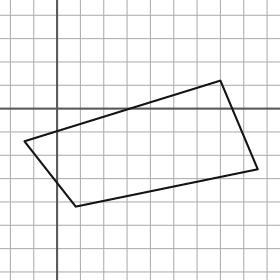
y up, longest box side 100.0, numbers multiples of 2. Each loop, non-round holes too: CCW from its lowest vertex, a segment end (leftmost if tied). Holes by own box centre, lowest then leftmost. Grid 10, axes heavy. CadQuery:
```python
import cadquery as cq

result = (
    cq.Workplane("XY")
    .moveTo(8.0, -42.0)
    .lineTo(86.0, -26.0)
    .lineTo(70.0, 12.0)
    .lineTo(-14.0, -14.0)
    .close()
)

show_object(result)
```